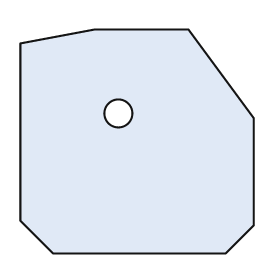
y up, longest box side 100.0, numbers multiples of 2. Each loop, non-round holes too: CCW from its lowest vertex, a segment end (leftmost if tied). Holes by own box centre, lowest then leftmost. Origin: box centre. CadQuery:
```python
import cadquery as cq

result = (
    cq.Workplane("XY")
    .moveTo(-36.0, -48.0)
    .lineTo(38.0, -48.0)
    .lineTo(50.0, -36.0)
    .lineTo(50.0, 10.0)
    .lineTo(22.0, 48.0)
    .lineTo(-18.0, 48.0)
    .lineTo(-50.0, 42.0)
    .lineTo(-50.0, -34.0)
    .close()
    .moveTo(-8.0, 12.0)
    .circle(6.0)
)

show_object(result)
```